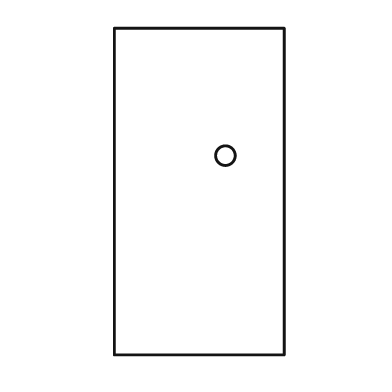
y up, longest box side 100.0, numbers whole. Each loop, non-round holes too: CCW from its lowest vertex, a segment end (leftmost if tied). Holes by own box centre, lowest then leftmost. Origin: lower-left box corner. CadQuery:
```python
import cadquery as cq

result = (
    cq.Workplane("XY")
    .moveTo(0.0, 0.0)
    .lineTo(52.0, 0.0)
    .lineTo(52.0, 100.0)
    .lineTo(0.0, 100.0)
    .close()
    .moveTo(34.0, 61.0)
    .circle(3.0)
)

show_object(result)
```